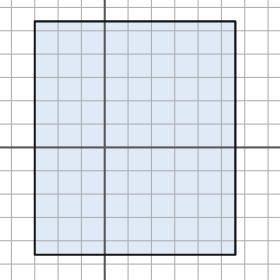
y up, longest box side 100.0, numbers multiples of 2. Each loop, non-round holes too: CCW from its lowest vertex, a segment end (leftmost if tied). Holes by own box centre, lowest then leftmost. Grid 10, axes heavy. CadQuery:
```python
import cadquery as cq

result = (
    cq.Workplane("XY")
    .moveTo(-30.0, -46.0)
    .lineTo(56.0, -46.0)
    .lineTo(56.0, 54.0)
    .lineTo(-30.0, 54.0)
    .close()
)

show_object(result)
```